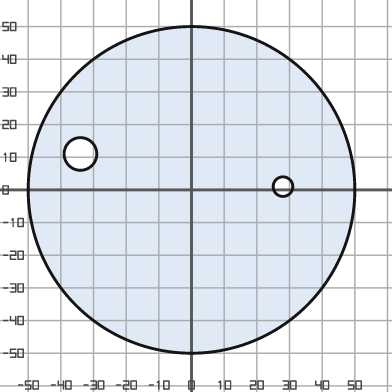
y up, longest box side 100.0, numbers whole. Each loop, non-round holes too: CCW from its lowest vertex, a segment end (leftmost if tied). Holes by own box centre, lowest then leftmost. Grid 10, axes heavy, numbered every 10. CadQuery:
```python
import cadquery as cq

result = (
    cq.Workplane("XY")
    .moveTo(0.0, 0.0)
    .circle(50.0)
    .moveTo(28.0, 1.0)
    .circle(3.0)
    .moveTo(-34.0, 11.0)
    .circle(5.0)
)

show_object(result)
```